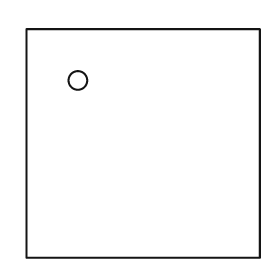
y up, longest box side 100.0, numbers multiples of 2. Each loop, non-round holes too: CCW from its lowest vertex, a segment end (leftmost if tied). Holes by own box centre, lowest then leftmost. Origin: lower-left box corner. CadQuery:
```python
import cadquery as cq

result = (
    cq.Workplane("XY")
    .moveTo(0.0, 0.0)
    .lineTo(100.0, 0.0)
    .lineTo(100.0, 98.0)
    .lineTo(0.0, 98.0)
    .close()
    .moveTo(22.0, 76.0)
    .circle(4.0)
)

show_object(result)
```